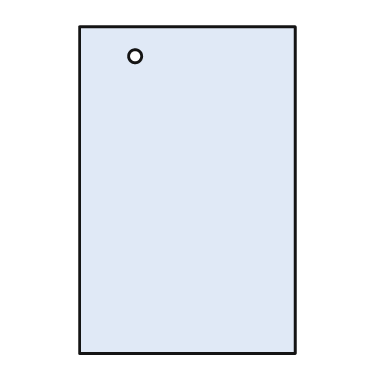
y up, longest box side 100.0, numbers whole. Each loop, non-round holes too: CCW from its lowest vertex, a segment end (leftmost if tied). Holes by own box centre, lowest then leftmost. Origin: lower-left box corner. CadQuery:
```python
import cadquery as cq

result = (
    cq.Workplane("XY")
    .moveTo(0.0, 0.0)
    .lineTo(66.0, 0.0)
    .lineTo(66.0, 100.0)
    .lineTo(0.0, 100.0)
    .close()
    .moveTo(17.0, 91.0)
    .circle(2.0)
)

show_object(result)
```